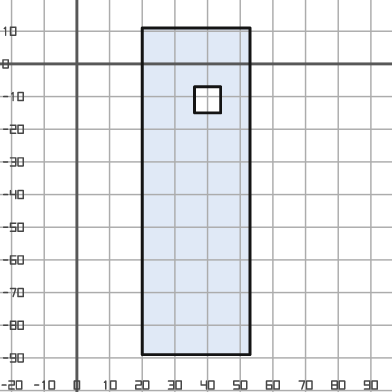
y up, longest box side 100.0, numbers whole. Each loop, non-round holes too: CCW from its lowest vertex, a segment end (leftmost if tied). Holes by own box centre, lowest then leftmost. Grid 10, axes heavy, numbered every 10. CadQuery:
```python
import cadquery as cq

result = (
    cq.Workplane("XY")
    .moveTo(20.0, -89.0)
    .lineTo(53.0, -89.0)
    .lineTo(53.0, 11.0)
    .lineTo(20.0, 11.0)
    .close()
    .moveTo(36.0, -15.0)
    .lineTo(44.0, -15.0)
    .lineTo(44.0, -7.0)
    .lineTo(36.0, -7.0)
    .close()
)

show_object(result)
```